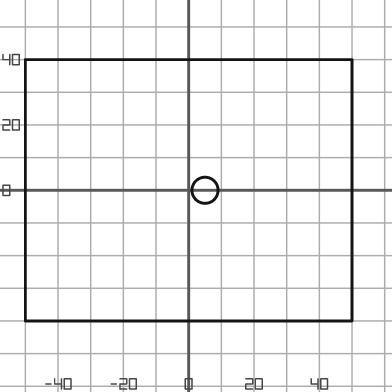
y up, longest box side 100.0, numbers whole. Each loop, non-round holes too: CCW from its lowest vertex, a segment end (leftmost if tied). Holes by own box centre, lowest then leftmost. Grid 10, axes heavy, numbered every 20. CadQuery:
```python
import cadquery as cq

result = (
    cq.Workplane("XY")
    .moveTo(-50.0, -40.0)
    .lineTo(50.0, -40.0)
    .lineTo(50.0, 40.0)
    .lineTo(-50.0, 40.0)
    .close()
    .moveTo(5.0, 0.0)
    .circle(4.0)
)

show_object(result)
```